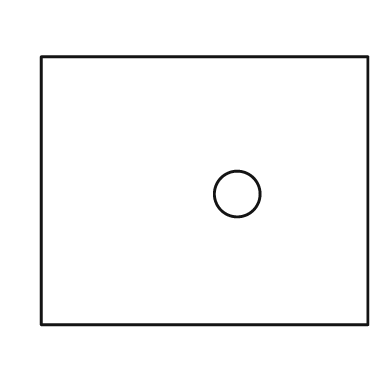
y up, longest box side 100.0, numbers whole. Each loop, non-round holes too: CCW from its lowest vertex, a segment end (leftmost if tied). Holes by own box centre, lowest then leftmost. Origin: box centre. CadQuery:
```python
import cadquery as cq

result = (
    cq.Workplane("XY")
    .moveTo(-50.0, -41.0)
    .lineTo(50.0, -41.0)
    .lineTo(50.0, 41.0)
    .lineTo(-50.0, 41.0)
    .close()
    .moveTo(10.0, -1.0)
    .circle(7.0)
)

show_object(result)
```